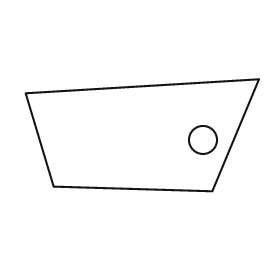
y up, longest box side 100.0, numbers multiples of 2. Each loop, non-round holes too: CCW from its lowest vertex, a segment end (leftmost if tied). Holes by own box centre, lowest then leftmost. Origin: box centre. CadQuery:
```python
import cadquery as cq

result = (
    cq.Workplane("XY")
    .moveTo(30.0, -24.0)
    .lineTo(50.0, 24.0)
    .lineTo(-50.0, 18.0)
    .lineTo(-38.0, -22.0)
    .close()
    .moveTo(26.0, -2.0)
    .circle(6.0)
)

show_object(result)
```